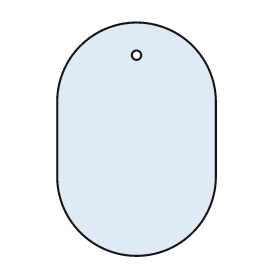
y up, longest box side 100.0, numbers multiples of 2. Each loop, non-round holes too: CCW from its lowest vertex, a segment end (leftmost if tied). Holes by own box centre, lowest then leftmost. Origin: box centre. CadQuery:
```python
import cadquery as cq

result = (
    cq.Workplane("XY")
    .moveTo(-34.0, -16.0)
    .threePointArc((0.0, -50.0), (34.0, -16.0))
    .lineTo(34.0, 16.0)
    .threePointArc((0.0, 50.0), (-34.0, 16.0))
    .close()
    .moveTo(0.0, 36.0)
    .circle(2.0)
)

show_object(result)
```